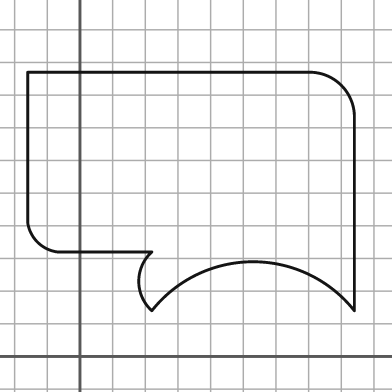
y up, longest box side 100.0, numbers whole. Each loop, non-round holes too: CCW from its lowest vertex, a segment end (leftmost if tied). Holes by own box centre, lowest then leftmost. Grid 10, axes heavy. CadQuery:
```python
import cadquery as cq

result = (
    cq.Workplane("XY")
    .moveTo(22.0, 14.0)
    .threePointArc((53.0, 29.0), (84.0, 14.0))
    .lineTo(84.0, 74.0)
    .threePointArc((80.0, 83.0), (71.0, 87.0))
    .lineTo(-16.0, 87.0)
    .lineTo(-16.0, 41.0)
    .threePointArc((-13.0, 35.0), (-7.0, 32.0))
    .lineTo(22.0, 32.0)
    .threePointArc((18.0, 23.0), (22.0, 14.0))
    .close()
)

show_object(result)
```